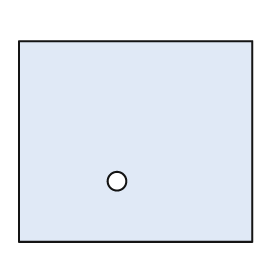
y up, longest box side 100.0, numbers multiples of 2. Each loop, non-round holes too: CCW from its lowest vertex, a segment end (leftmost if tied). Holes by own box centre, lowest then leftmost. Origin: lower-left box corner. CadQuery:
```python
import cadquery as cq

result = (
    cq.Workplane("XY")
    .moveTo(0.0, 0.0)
    .lineTo(100.0, 0.0)
    .lineTo(100.0, 86.0)
    .lineTo(0.0, 86.0)
    .close()
    .moveTo(42.0, 26.0)
    .circle(4.0)
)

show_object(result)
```